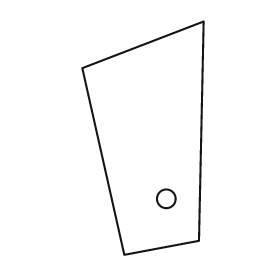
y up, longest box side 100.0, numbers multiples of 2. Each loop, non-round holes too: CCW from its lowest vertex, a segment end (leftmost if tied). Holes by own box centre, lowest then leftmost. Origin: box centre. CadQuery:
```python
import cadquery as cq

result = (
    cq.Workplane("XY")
    .moveTo(-8.0, -50.0)
    .lineTo(24.0, -44.0)
    .lineTo(26.0, 50.0)
    .lineTo(-26.0, 30.0)
    .close()
    .moveTo(10.0, -26.0)
    .circle(4.0)
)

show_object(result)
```